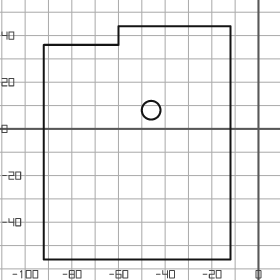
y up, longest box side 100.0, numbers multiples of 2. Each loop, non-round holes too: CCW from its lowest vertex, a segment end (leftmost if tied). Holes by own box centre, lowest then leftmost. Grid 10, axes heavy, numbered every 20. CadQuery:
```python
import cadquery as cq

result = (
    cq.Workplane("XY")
    .moveTo(-92.0, -56.0)
    .lineTo(-12.0, -56.0)
    .lineTo(-12.0, 44.0)
    .lineTo(-60.0, 44.0)
    .lineTo(-60.0, 36.0)
    .lineTo(-92.0, 36.0)
    .close()
    .moveTo(-46.0, 8.0)
    .circle(4.0)
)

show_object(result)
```